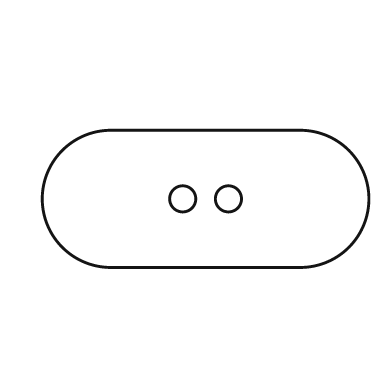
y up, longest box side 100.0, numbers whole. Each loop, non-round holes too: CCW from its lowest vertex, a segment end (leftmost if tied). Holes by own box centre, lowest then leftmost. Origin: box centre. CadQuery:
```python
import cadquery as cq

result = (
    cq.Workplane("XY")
    .moveTo(-29.0, -21.0)
    .lineTo(29.0, -21.0)
    .threePointArc((50.0, 0.0), (29.0, 21.0))
    .lineTo(-29.0, 21.0)
    .threePointArc((-50.0, 0.0), (-29.0, -21.0))
    .close()
    .moveTo(-7.0, 0.0)
    .circle(4.0)
    .moveTo(7.0, 0.0)
    .circle(4.0)
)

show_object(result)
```